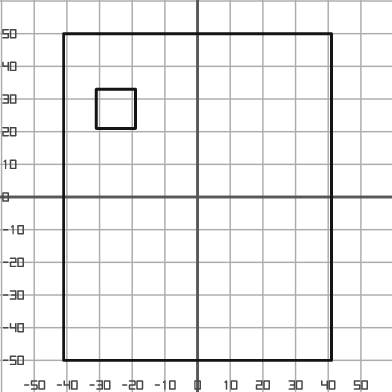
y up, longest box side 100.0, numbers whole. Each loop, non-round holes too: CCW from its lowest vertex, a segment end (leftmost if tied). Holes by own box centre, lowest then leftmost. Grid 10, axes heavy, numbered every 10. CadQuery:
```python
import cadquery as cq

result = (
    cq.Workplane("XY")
    .moveTo(-41.0, -50.0)
    .lineTo(41.0, -50.0)
    .lineTo(41.0, 50.0)
    .lineTo(-41.0, 50.0)
    .close()
    .moveTo(-31.0, 21.0)
    .lineTo(-19.0, 21.0)
    .lineTo(-19.0, 33.0)
    .lineTo(-31.0, 33.0)
    .close()
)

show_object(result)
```